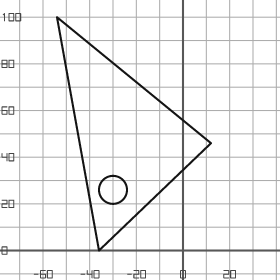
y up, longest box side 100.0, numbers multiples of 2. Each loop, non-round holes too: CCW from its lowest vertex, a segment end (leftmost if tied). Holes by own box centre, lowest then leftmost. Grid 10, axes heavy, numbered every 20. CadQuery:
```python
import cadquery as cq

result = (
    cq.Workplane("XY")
    .moveTo(-36.0, 0.0)
    .lineTo(12.0, 46.0)
    .lineTo(-54.0, 100.0)
    .close()
    .moveTo(-30.0, 26.0)
    .circle(6.0)
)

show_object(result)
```